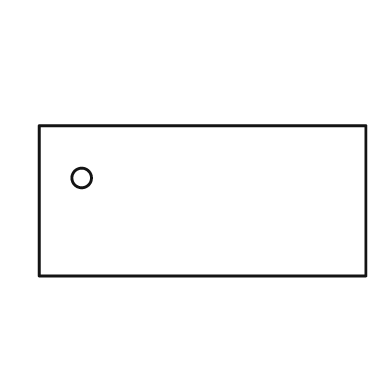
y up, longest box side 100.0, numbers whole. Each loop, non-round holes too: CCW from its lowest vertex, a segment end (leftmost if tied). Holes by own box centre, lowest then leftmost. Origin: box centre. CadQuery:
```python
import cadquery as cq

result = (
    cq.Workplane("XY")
    .moveTo(-50.0, -23.0)
    .lineTo(50.0, -23.0)
    .lineTo(50.0, 23.0)
    .lineTo(-50.0, 23.0)
    .close()
    .moveTo(-37.0, 7.0)
    .circle(3.0)
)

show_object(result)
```